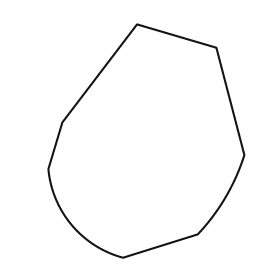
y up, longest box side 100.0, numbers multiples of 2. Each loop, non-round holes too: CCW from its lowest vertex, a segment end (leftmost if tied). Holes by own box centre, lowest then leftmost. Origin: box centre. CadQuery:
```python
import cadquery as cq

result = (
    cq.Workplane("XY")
    .moveTo(-10.0, -50.0)
    .lineTo(22.0, -40.0)
    .threePointArc((34.0, -24.0), (42.0, -6.0))
    .lineTo(30.0, 40.0)
    .lineTo(-4.0, 50.0)
    .lineTo(-36.0, 8.0)
    .lineTo(-42.0, -12.0)
    .threePointArc((-32.0, -36.0), (-10.0, -50.0))
    .close()
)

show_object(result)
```